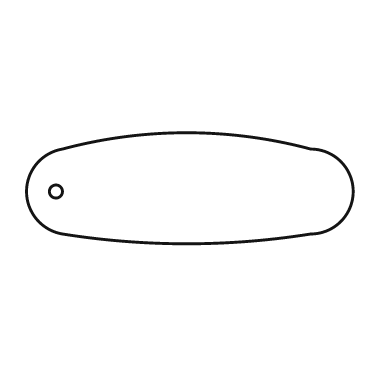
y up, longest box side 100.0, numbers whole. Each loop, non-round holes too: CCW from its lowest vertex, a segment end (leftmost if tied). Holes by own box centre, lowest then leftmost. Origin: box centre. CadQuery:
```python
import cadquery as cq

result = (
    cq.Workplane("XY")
    .moveTo(-39.0, -14.0)
    .threePointArc((-1.0, -17.0), (37.0, -14.0))
    .threePointArc((50.0, -1.0), (37.0, 12.0))
    .threePointArc((-1.0, 17.0), (-39.0, 12.0))
    .threePointArc((-50.0, -1.0), (-39.0, -14.0))
    .close()
    .moveTo(-41.0, -1.0)
    .circle(2.0)
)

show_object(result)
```